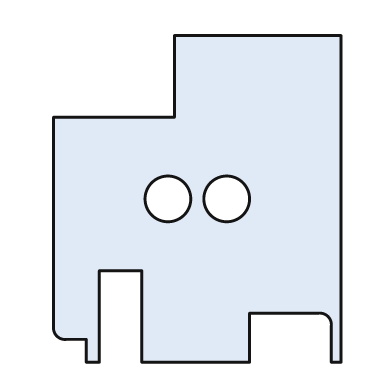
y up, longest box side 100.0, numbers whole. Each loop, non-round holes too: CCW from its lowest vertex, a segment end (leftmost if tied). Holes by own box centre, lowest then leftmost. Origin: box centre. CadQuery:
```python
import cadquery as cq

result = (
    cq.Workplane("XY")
    .moveTo(-34.0, -50.0)
    .lineTo(-30.0, -50.0)
    .lineTo(-30.0, -22.0)
    .lineTo(-17.0, -22.0)
    .lineTo(-17.0, -50.0)
    .lineTo(16.0, -50.0)
    .lineTo(16.0, -35.0)
    .lineTo(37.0, -35.0)
    .threePointArc((40.0, -36.0), (41.0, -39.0))
    .lineTo(41.0, -50.0)
    .lineTo(44.0, -50.0)
    .lineTo(44.0, 50.0)
    .lineTo(-7.0, 50.0)
    .lineTo(-7.0, 25.0)
    .lineTo(-44.0, 25.0)
    .lineTo(-44.0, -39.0)
    .threePointArc((-43.0, -42.0), (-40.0, -43.0))
    .lineTo(-34.0, -43.0)
    .close()
    .moveTo(-9.0, 0.0)
    .circle(7.0)
    .moveTo(9.0, 0.0)
    .circle(7.0)
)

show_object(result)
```